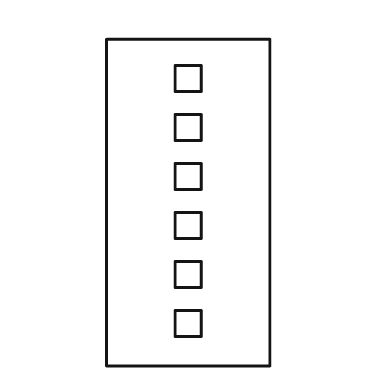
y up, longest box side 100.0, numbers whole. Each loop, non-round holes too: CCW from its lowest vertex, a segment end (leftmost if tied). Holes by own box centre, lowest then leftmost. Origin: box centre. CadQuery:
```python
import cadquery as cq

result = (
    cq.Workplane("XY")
    .moveTo(-25.0, -50.0)
    .lineTo(25.0, -50.0)
    .lineTo(25.0, 50.0)
    .lineTo(-25.0, 50.0)
    .close()
    .moveTo(-4.0, -41.0)
    .lineTo(4.0, -41.0)
    .lineTo(4.0, -33.0)
    .lineTo(-4.0, -33.0)
    .close()
    .moveTo(-4.0, -26.0)
    .lineTo(4.0, -26.0)
    .lineTo(4.0, -18.0)
    .lineTo(-4.0, -18.0)
    .close()
    .moveTo(-4.0, -11.0)
    .lineTo(4.0, -11.0)
    .lineTo(4.0, -3.0)
    .lineTo(-4.0, -3.0)
    .close()
    .moveTo(-4.0, 4.0)
    .lineTo(4.0, 4.0)
    .lineTo(4.0, 12.0)
    .lineTo(-4.0, 12.0)
    .close()
    .moveTo(-4.0, 19.0)
    .lineTo(4.0, 19.0)
    .lineTo(4.0, 27.0)
    .lineTo(-4.0, 27.0)
    .close()
    .moveTo(-4.0, 34.0)
    .lineTo(4.0, 34.0)
    .lineTo(4.0, 42.0)
    .lineTo(-4.0, 42.0)
    .close()
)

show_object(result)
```